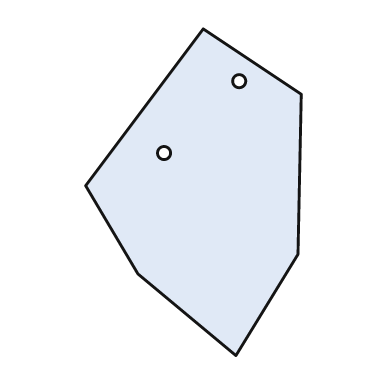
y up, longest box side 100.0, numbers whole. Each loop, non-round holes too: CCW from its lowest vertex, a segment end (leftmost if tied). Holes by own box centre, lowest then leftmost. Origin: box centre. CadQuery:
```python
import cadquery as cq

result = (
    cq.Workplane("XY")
    .moveTo(13.0, -50.0)
    .lineTo(32.0, -19.0)
    .lineTo(33.0, 30.0)
    .lineTo(3.0, 50.0)
    .lineTo(-33.0, 2.0)
    .lineTo(-17.0, -25.0)
    .close()
    .moveTo(-9.0, 12.0)
    .circle(2.0)
    .moveTo(14.0, 34.0)
    .circle(2.0)
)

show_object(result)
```